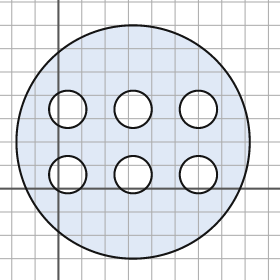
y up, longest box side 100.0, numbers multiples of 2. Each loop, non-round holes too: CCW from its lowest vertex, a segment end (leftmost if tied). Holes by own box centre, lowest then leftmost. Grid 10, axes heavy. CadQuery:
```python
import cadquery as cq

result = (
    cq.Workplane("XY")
    .moveTo(32.0, 20.0)
    .circle(50.0)
    .moveTo(4.0, 6.0)
    .circle(8.0)
    .moveTo(32.0, 6.0)
    .circle(8.0)
    .moveTo(60.0, 6.0)
    .circle(8.0)
    .moveTo(4.0, 34.0)
    .circle(8.0)
    .moveTo(32.0, 34.0)
    .circle(8.0)
    .moveTo(60.0, 34.0)
    .circle(8.0)
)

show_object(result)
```